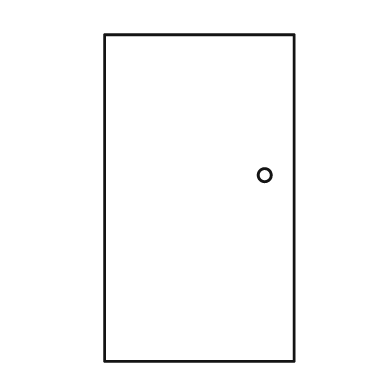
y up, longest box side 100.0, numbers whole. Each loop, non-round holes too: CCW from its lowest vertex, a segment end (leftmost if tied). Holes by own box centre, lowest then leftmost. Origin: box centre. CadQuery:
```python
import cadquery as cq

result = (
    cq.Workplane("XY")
    .moveTo(-29.0, -50.0)
    .lineTo(29.0, -50.0)
    .lineTo(29.0, 50.0)
    .lineTo(-29.0, 50.0)
    .close()
    .moveTo(20.0, 7.0)
    .circle(2.0)
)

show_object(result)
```